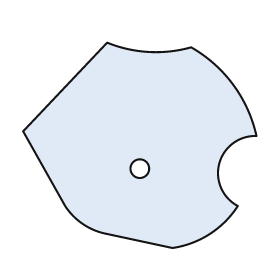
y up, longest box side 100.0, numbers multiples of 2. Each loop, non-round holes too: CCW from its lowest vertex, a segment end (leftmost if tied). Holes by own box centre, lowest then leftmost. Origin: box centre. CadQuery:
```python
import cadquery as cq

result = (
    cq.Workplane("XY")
    .moveTo(14.0, -44.0)
    .threePointArc((30.0, -38.0), (42.0, -26.0))
    .threePointArc((34.0, -8.0), (50.0, 4.0))
    .threePointArc((40.0, 26.0), (22.0, 42.0))
    .threePointArc((4.0, 40.0), (-14.0, 44.0))
    .lineTo(-50.0, 6.0)
    .lineTo(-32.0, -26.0)
    .threePointArc((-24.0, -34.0), (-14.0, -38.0))
    .close()
    .moveTo(0.0, -10.0)
    .circle(4.0)
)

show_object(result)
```